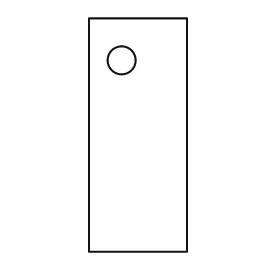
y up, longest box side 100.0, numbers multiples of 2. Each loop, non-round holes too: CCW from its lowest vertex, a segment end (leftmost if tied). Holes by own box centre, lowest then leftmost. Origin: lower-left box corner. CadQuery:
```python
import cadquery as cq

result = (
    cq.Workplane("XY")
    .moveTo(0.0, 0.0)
    .lineTo(42.0, 0.0)
    .lineTo(42.0, 100.0)
    .lineTo(0.0, 100.0)
    .close()
    .moveTo(14.0, 82.0)
    .circle(6.0)
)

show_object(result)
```